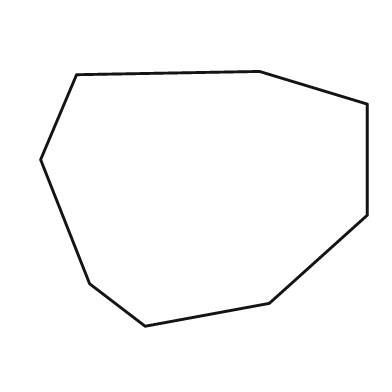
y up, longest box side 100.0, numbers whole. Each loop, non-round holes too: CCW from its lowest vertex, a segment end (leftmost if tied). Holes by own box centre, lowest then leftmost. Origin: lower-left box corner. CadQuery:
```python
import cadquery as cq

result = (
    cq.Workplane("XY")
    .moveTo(32.0, 0.0)
    .lineTo(70.0, 7.0)
    .lineTo(100.0, 34.0)
    .lineTo(100.0, 68.0)
    .lineTo(67.0, 78.0)
    .lineTo(11.0, 77.0)
    .lineTo(0.0, 51.0)
    .lineTo(15.0, 13.0)
    .close()
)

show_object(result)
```